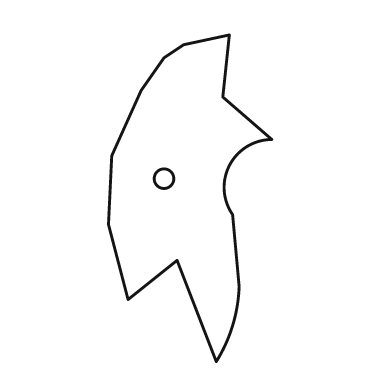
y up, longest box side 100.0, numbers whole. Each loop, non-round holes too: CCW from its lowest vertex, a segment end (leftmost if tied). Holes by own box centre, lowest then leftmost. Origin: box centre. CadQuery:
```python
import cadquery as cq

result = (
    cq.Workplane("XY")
    .moveTo(8.0, -50.0)
    .threePointArc((13.0, -39.0), (15.0, -27.0))
    .lineTo(13.0, -5.0)
    .threePointArc((12.0, 10.0), (25.0, 18.0))
    .lineTo(10.0, 31.0)
    .lineTo(12.0, 50.0)
    .lineTo(-2.0, 47.0)
    .lineTo(-8.0, 43.0)
    .lineTo(-15.0, 33.0)
    .lineTo(-24.0, 13.0)
    .lineTo(-25.0, -8.0)
    .lineTo(-19.0, -31.0)
    .lineTo(-4.0, -19.0)
    .close()
    .moveTo(-8.0, 6.0)
    .circle(3.0)
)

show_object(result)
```